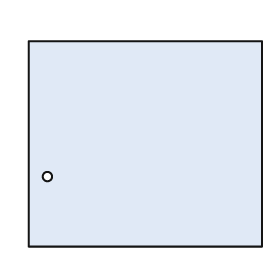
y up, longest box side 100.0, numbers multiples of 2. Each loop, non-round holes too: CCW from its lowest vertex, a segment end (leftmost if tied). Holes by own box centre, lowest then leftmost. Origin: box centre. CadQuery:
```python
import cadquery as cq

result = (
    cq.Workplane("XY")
    .moveTo(-50.0, -44.0)
    .lineTo(50.0, -44.0)
    .lineTo(50.0, 44.0)
    .lineTo(-50.0, 44.0)
    .close()
    .moveTo(-42.0, -14.0)
    .circle(2.0)
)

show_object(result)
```